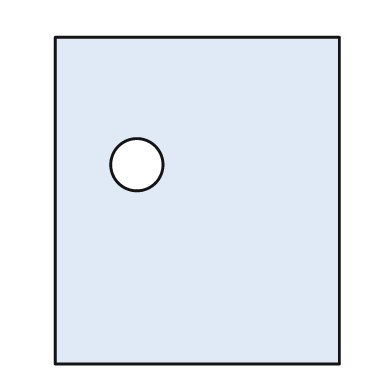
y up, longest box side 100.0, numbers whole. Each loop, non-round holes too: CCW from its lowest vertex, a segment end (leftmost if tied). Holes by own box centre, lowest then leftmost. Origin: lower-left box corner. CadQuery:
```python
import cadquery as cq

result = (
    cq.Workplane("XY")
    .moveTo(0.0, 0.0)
    .lineTo(87.0, 0.0)
    .lineTo(87.0, 100.0)
    .lineTo(0.0, 100.0)
    .close()
    .moveTo(25.0, 61.0)
    .circle(8.0)
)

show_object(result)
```